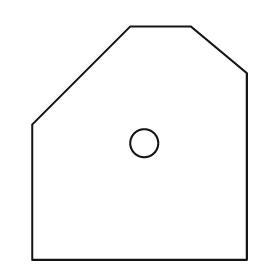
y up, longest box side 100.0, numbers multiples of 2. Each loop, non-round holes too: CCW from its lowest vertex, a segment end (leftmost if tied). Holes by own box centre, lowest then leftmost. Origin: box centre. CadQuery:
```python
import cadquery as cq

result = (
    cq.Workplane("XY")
    .moveTo(-46.0, -50.0)
    .lineTo(46.0, -50.0)
    .lineTo(46.0, 30.0)
    .lineTo(22.0, 50.0)
    .lineTo(-4.0, 50.0)
    .lineTo(-46.0, 8.0)
    .close()
    .moveTo(2.0, 0.0)
    .circle(6.0)
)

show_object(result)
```